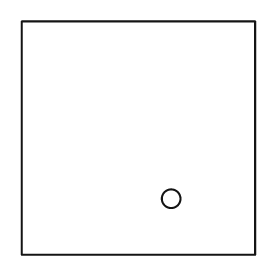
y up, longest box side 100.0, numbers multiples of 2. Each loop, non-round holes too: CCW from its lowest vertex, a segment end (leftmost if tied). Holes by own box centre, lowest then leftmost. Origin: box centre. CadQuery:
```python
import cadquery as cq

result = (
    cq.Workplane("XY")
    .moveTo(-50.0, -50.0)
    .lineTo(50.0, -50.0)
    .lineTo(50.0, 50.0)
    .lineTo(-50.0, 50.0)
    .close()
    .moveTo(14.0, -26.0)
    .circle(4.0)
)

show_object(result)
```